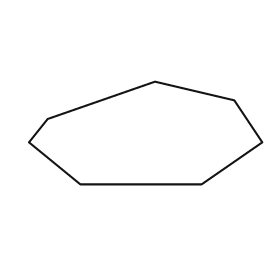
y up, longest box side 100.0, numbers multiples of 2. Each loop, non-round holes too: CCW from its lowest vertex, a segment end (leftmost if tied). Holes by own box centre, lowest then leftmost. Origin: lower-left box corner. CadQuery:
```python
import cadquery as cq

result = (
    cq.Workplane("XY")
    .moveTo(22.0, 0.0)
    .lineTo(74.0, 0.0)
    .lineTo(100.0, 18.0)
    .lineTo(88.0, 36.0)
    .lineTo(54.0, 44.0)
    .lineTo(8.0, 28.0)
    .lineTo(0.0, 18.0)
    .close()
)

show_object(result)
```